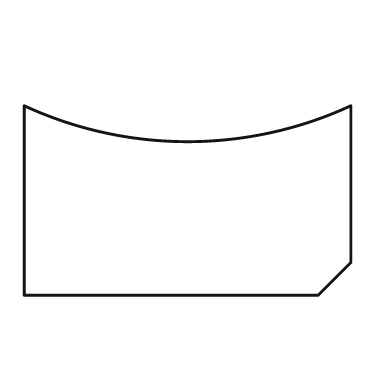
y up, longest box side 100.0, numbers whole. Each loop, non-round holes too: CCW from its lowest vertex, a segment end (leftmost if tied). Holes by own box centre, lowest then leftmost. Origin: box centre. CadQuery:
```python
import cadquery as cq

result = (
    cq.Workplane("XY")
    .moveTo(-50.0, -29.0)
    .lineTo(40.0, -29.0)
    .lineTo(50.0, -19.0)
    .lineTo(50.0, 29.0)
    .threePointArc((0.0, 18.0), (-50.0, 29.0))
    .close()
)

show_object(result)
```